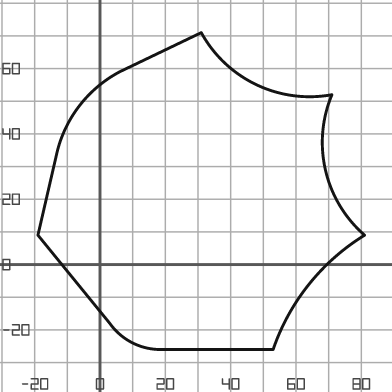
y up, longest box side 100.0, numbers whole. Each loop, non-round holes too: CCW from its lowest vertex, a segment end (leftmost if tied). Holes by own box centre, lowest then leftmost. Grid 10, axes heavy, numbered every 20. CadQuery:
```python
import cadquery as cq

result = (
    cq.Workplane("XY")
    .moveTo(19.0, -26.0)
    .lineTo(53.0, -26.0)
    .threePointArc((64.0, -6.0), (81.0, 9.0))
    .threePointArc((69.0, 29.0), (71.0, 52.0))
    .threePointArc((48.0, 55.0), (31.0, 71.0))
    .lineTo(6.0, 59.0)
    .threePointArc((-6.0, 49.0), (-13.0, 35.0))
    .lineTo(-19.0, 9.0)
    .lineTo(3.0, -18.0)
    .threePointArc((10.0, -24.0), (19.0, -26.0))
    .close()
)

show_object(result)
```